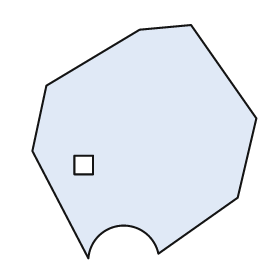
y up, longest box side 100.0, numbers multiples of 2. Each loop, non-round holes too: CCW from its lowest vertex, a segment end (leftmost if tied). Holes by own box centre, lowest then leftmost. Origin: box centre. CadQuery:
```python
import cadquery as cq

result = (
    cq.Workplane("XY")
    .moveTo(-24.0, -50.0)
    .threePointArc((-10.0, -36.0), (6.0, -48.0))
    .lineTo(40.0, -24.0)
    .lineTo(48.0, 10.0)
    .lineTo(20.0, 50.0)
    .lineTo(-2.0, 48.0)
    .lineTo(-42.0, 24.0)
    .lineTo(-48.0, -4.0)
    .close()
    .moveTo(-30.0, -14.0)
    .lineTo(-22.0, -14.0)
    .lineTo(-22.0, -6.0)
    .lineTo(-30.0, -6.0)
    .close()
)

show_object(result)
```